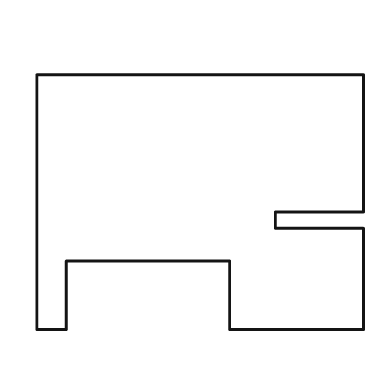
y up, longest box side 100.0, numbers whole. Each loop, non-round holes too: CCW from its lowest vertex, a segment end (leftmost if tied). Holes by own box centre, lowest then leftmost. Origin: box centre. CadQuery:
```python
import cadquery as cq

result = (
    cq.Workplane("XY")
    .moveTo(-50.0, -39.0)
    .lineTo(-41.0, -39.0)
    .lineTo(-41.0, -18.0)
    .lineTo(9.0, -18.0)
    .lineTo(9.0, -39.0)
    .lineTo(50.0, -39.0)
    .lineTo(50.0, -8.0)
    .lineTo(23.0, -8.0)
    .lineTo(23.0, -3.0)
    .lineTo(50.0, -3.0)
    .lineTo(50.0, 39.0)
    .lineTo(-50.0, 39.0)
    .close()
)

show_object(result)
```